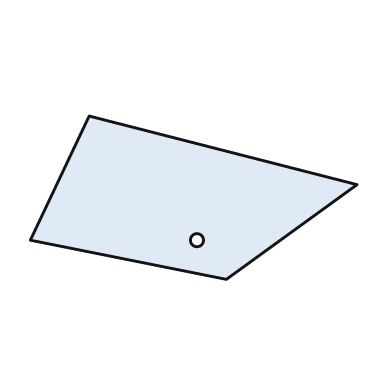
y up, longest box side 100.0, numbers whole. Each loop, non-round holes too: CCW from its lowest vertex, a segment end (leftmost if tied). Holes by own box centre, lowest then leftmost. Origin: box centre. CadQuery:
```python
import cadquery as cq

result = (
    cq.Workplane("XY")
    .moveTo(10.0, -25.0)
    .lineTo(50.0, 4.0)
    .lineTo(-32.0, 25.0)
    .lineTo(-50.0, -13.0)
    .close()
    .moveTo(1.0, -13.0)
    .circle(2.0)
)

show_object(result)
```